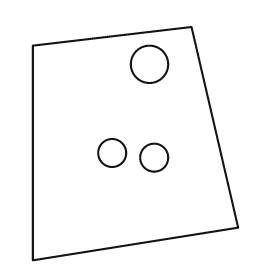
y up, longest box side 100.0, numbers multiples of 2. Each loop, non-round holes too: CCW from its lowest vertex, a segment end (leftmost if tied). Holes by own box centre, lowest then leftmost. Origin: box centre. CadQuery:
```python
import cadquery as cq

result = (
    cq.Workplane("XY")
    .moveTo(-44.0, -50.0)
    .lineTo(44.0, -36.0)
    .lineTo(24.0, 50.0)
    .lineTo(-44.0, 42.0)
    .close()
    .moveTo(8.0, -6.0)
    .circle(6.0)
    .moveTo(-10.0, -4.0)
    .circle(6.0)
    .moveTo(6.0, 34.0)
    .circle(8.0)
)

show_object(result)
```